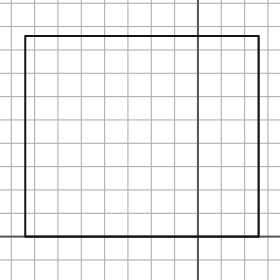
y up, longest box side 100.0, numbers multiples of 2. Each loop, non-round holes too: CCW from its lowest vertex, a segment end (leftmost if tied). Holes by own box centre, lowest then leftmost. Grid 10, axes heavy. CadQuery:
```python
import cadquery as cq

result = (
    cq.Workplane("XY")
    .moveTo(-74.0, 0.0)
    .lineTo(26.0, 0.0)
    .lineTo(26.0, 86.0)
    .lineTo(-74.0, 86.0)
    .close()
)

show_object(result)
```